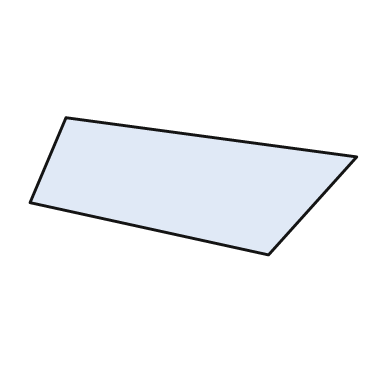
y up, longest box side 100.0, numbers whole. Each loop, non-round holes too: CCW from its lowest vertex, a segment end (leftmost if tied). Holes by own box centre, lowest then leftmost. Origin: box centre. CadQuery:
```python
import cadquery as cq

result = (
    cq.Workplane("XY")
    .moveTo(23.0, -21.0)
    .lineTo(50.0, 9.0)
    .lineTo(-39.0, 21.0)
    .lineTo(-50.0, -5.0)
    .close()
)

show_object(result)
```